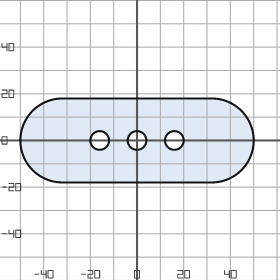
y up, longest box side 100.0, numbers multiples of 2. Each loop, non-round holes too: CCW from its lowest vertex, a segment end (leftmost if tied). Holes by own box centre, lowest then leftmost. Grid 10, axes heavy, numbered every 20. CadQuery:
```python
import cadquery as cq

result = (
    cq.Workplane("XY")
    .moveTo(-32.0, -18.0)
    .lineTo(32.0, -18.0)
    .threePointArc((50.0, 0.0), (32.0, 18.0))
    .lineTo(-32.0, 18.0)
    .threePointArc((-50.0, 0.0), (-32.0, -18.0))
    .close()
    .moveTo(-16.0, 0.0)
    .circle(4.0)
    .moveTo(0.0, 0.0)
    .circle(4.0)
    .moveTo(16.0, 0.0)
    .circle(4.0)
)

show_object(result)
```